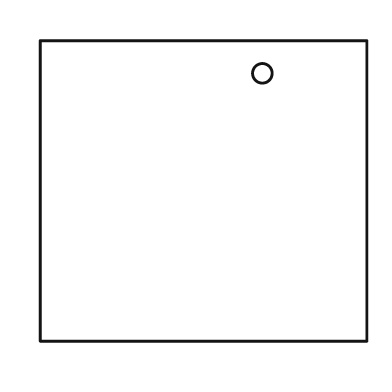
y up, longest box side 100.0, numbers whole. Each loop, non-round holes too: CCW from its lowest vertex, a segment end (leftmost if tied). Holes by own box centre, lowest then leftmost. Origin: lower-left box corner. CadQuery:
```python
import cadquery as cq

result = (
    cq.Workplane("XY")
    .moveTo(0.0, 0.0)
    .lineTo(100.0, 0.0)
    .lineTo(100.0, 92.0)
    .lineTo(0.0, 92.0)
    .close()
    .moveTo(68.0, 82.0)
    .circle(3.0)
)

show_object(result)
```